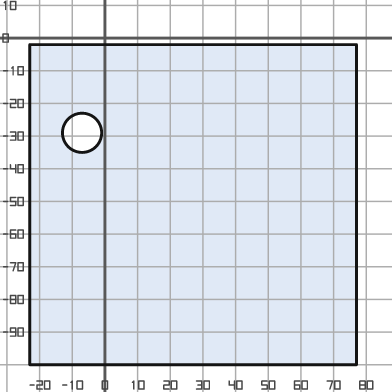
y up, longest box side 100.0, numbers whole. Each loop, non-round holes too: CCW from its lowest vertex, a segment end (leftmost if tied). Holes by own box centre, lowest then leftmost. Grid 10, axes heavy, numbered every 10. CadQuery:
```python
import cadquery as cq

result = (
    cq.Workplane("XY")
    .moveTo(-23.0, -100.0)
    .lineTo(77.0, -100.0)
    .lineTo(77.0, -2.0)
    .lineTo(-23.0, -2.0)
    .close()
    .moveTo(-7.0, -29.0)
    .circle(6.0)
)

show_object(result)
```